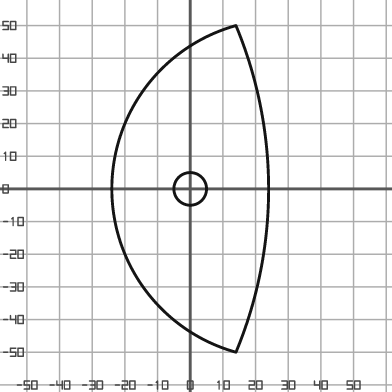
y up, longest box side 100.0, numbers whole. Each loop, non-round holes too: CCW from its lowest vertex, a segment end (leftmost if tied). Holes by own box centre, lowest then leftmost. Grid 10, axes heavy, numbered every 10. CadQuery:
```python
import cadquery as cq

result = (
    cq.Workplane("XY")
    .moveTo(14.0, -50.0)
    .threePointArc((24.0, 0.0), (14.0, 50.0))
    .threePointArc((-24.0, 0.0), (14.0, -50.0))
    .close()
    .moveTo(0.0, 0.0)
    .circle(5.0)
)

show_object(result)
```